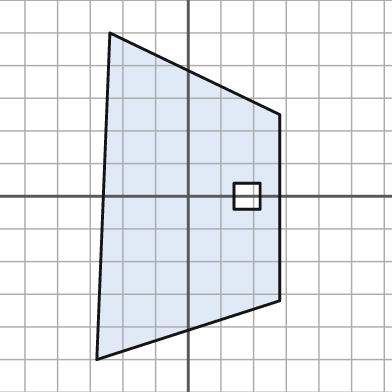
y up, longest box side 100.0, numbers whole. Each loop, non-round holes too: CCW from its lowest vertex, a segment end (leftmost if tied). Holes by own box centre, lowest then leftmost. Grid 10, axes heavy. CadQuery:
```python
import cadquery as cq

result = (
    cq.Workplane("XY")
    .moveTo(-28.0, -50.0)
    .lineTo(28.0, -32.0)
    .lineTo(28.0, 25.0)
    .lineTo(-24.0, 50.0)
    .close()
    .moveTo(14.0, -4.0)
    .lineTo(22.0, -4.0)
    .lineTo(22.0, 4.0)
    .lineTo(14.0, 4.0)
    .close()
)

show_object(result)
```